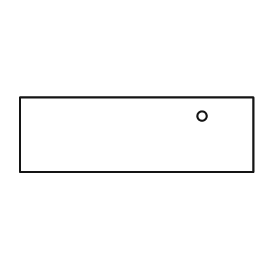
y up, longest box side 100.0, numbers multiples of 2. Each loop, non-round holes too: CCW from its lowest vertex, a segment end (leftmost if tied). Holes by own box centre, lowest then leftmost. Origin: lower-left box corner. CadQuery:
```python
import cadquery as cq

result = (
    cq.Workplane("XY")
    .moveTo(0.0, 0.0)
    .lineTo(100.0, 0.0)
    .lineTo(100.0, 32.0)
    .lineTo(0.0, 32.0)
    .close()
    .moveTo(78.0, 24.0)
    .circle(2.0)
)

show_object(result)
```